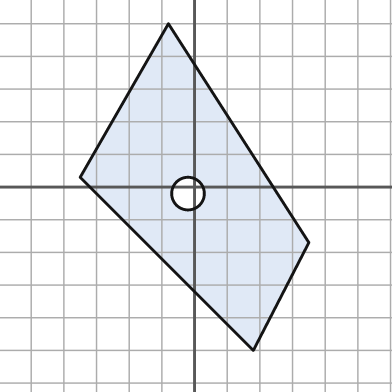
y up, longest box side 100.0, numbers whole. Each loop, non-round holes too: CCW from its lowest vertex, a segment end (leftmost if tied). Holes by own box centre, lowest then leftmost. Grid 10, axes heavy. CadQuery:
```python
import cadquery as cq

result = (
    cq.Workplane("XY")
    .moveTo(18.0, -50.0)
    .lineTo(35.0, -17.0)
    .lineTo(-8.0, 50.0)
    .lineTo(-35.0, 3.0)
    .close()
    .moveTo(-2.0, -2.0)
    .circle(5.0)
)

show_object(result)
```